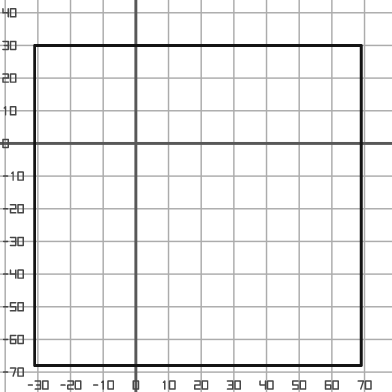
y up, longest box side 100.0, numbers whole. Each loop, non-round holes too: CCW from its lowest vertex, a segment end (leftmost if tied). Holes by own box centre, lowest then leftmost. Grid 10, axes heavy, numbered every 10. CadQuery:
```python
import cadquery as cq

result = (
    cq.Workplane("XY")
    .moveTo(-31.0, -68.0)
    .lineTo(69.0, -68.0)
    .lineTo(69.0, 30.0)
    .lineTo(-31.0, 30.0)
    .close()
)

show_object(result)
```